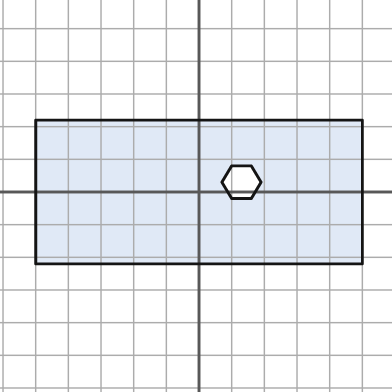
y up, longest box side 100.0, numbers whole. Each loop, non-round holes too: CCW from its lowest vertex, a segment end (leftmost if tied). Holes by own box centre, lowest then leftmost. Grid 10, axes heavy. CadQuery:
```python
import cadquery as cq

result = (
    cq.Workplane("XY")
    .moveTo(-50.0, -22.0)
    .lineTo(50.0, -22.0)
    .lineTo(50.0, 22.0)
    .lineTo(-50.0, 22.0)
    .close()
    .moveTo(10.0, -2.0)
    .lineTo(16.0, -2.0)
    .lineTo(19.0, 3.0)
    .lineTo(16.0, 8.0)
    .lineTo(10.0, 8.0)
    .lineTo(7.0, 3.0)
    .close()
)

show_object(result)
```